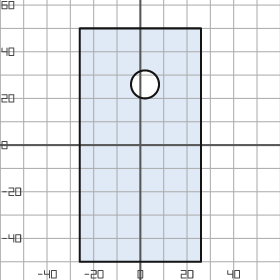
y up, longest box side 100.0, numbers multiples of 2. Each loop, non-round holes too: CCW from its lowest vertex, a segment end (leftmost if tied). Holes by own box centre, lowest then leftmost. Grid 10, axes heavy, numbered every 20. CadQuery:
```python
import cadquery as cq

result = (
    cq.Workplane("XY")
    .moveTo(-26.0, -50.0)
    .lineTo(26.0, -50.0)
    .lineTo(26.0, 50.0)
    .lineTo(-26.0, 50.0)
    .close()
    .moveTo(2.0, 26.0)
    .circle(6.0)
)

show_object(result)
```